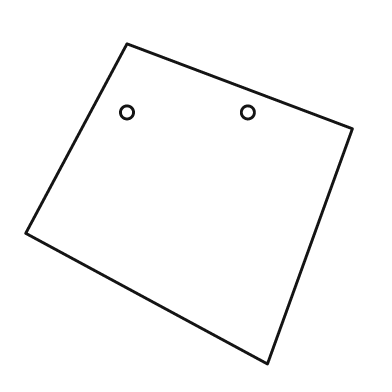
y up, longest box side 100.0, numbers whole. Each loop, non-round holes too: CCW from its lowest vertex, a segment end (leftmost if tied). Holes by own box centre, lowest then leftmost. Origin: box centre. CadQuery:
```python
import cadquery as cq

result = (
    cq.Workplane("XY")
    .moveTo(24.0, -49.0)
    .lineTo(50.0, 23.0)
    .lineTo(-19.0, 49.0)
    .lineTo(-50.0, -9.0)
    .close()
    .moveTo(-19.0, 28.0)
    .circle(2.0)
    .moveTo(18.0, 28.0)
    .circle(2.0)
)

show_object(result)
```